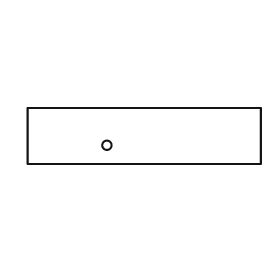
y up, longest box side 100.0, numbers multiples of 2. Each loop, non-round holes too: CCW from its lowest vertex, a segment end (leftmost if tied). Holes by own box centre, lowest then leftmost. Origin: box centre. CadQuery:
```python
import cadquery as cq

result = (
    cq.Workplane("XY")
    .moveTo(-50.0, -12.0)
    .lineTo(50.0, -12.0)
    .lineTo(50.0, 12.0)
    .lineTo(-50.0, 12.0)
    .close()
    .moveTo(-16.0, -4.0)
    .circle(2.0)
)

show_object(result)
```